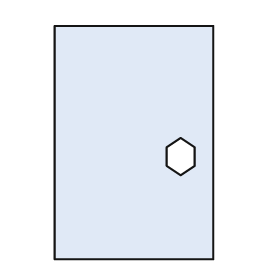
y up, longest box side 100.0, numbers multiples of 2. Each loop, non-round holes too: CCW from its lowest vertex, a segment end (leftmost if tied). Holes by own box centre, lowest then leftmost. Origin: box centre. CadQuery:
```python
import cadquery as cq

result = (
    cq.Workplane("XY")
    .moveTo(-34.0, -50.0)
    .lineTo(34.0, -50.0)
    .lineTo(34.0, 50.0)
    .lineTo(-34.0, 50.0)
    .close()
    .moveTo(20.0, -14.0)
    .lineTo(26.0, -10.0)
    .lineTo(26.0, -2.0)
    .lineTo(20.0, 2.0)
    .lineTo(14.0, -2.0)
    .lineTo(14.0, -10.0)
    .close()
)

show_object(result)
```